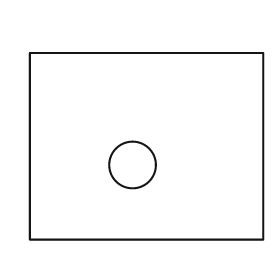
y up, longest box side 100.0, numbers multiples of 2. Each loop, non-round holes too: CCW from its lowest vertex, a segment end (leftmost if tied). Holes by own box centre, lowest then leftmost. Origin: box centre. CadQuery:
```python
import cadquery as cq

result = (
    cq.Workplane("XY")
    .moveTo(-50.0, -40.0)
    .lineTo(50.0, -40.0)
    .lineTo(50.0, 40.0)
    .lineTo(-50.0, 40.0)
    .close()
    .moveTo(-6.0, -8.0)
    .circle(10.0)
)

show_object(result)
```